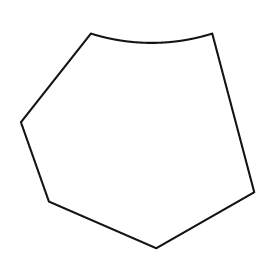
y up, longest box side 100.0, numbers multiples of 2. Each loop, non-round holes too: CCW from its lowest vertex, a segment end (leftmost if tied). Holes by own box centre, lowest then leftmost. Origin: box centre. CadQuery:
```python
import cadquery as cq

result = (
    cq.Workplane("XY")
    .moveTo(8.0, -46.0)
    .lineTo(50.0, -22.0)
    .lineTo(32.0, 46.0)
    .threePointArc((6.0, 42.0), (-20.0, 46.0))
    .lineTo(-50.0, 8.0)
    .lineTo(-38.0, -26.0)
    .close()
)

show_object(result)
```